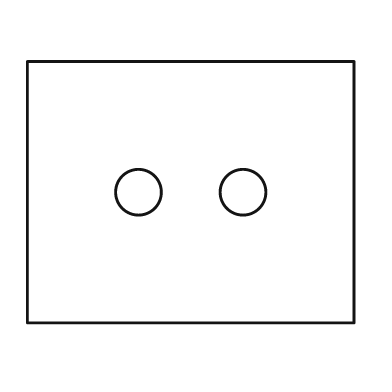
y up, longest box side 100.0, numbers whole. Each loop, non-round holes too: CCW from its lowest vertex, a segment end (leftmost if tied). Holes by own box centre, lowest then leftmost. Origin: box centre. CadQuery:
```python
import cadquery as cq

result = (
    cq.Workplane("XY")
    .moveTo(-50.0, -40.0)
    .lineTo(50.0, -40.0)
    .lineTo(50.0, 40.0)
    .lineTo(-50.0, 40.0)
    .close()
    .moveTo(-16.0, 0.0)
    .circle(7.0)
    .moveTo(16.0, 0.0)
    .circle(7.0)
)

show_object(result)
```